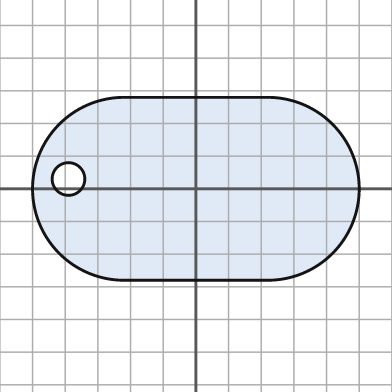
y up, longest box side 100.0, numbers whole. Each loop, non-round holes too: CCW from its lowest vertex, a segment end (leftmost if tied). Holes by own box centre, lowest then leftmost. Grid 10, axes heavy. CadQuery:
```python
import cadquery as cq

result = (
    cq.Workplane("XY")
    .moveTo(-22.0, -28.0)
    .lineTo(22.0, -28.0)
    .threePointArc((50.0, 0.0), (22.0, 28.0))
    .lineTo(-22.0, 28.0)
    .threePointArc((-50.0, 0.0), (-22.0, -28.0))
    .close()
    .moveTo(-39.0, 3.0)
    .circle(5.0)
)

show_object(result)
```